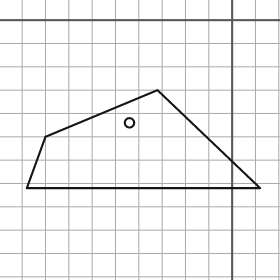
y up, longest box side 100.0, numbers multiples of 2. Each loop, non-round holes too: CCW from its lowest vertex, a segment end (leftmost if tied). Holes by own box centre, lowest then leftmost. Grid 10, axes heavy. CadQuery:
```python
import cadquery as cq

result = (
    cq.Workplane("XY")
    .moveTo(-88.0, -72.0)
    .lineTo(12.0, -72.0)
    .lineTo(-32.0, -30.0)
    .lineTo(-80.0, -50.0)
    .close()
    .moveTo(-44.0, -44.0)
    .circle(2.0)
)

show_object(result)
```